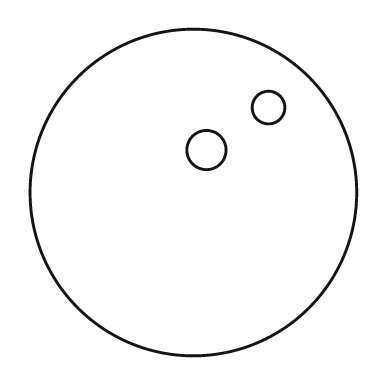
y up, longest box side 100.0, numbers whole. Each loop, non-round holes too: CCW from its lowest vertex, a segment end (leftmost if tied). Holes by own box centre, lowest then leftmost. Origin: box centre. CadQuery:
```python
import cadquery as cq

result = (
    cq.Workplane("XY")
    .moveTo(0.0, 0.0)
    .circle(50.0)
    .moveTo(4.0, 13.0)
    .circle(6.0)
    .moveTo(23.0, 26.0)
    .circle(5.0)
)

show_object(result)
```